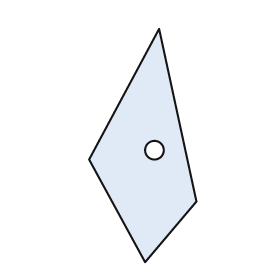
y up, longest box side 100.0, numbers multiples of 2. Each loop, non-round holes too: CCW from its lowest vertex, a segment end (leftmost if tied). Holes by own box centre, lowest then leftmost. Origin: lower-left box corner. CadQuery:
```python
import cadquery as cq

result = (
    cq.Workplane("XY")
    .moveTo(24.0, 0.0)
    .lineTo(46.0, 26.0)
    .lineTo(30.0, 100.0)
    .lineTo(0.0, 44.0)
    .close()
    .moveTo(28.0, 48.0)
    .circle(4.0)
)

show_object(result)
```